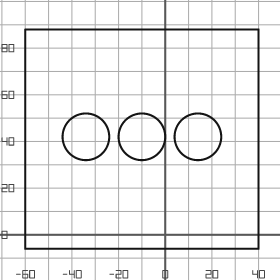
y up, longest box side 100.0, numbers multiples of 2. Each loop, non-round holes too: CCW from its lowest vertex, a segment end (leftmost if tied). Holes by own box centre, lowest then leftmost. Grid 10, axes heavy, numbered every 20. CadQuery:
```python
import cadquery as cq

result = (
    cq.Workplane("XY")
    .moveTo(-60.0, -6.0)
    .lineTo(40.0, -6.0)
    .lineTo(40.0, 88.0)
    .lineTo(-60.0, 88.0)
    .close()
    .moveTo(-34.0, 42.0)
    .circle(10.0)
    .moveTo(-10.0, 42.0)
    .circle(10.0)
    .moveTo(14.0, 42.0)
    .circle(10.0)
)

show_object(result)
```